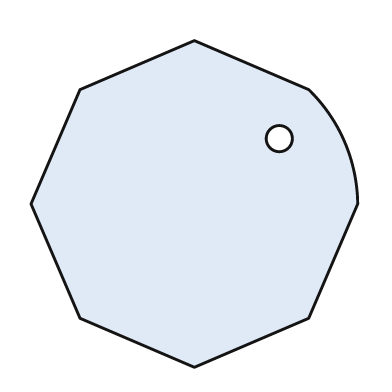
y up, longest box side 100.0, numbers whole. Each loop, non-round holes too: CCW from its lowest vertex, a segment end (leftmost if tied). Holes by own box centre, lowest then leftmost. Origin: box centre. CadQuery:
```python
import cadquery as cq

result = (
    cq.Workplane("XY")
    .moveTo(0.0, -50.0)
    .lineTo(35.0, -35.0)
    .lineTo(50.0, 0.0)
    .threePointArc((46.0, 19.0), (35.0, 35.0))
    .lineTo(0.0, 50.0)
    .lineTo(-35.0, 35.0)
    .lineTo(-50.0, 0.0)
    .lineTo(-35.0, -35.0)
    .close()
    .moveTo(26.0, 20.0)
    .circle(4.0)
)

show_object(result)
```